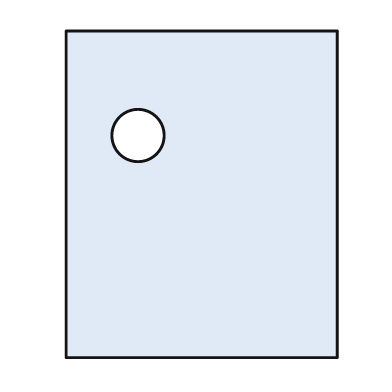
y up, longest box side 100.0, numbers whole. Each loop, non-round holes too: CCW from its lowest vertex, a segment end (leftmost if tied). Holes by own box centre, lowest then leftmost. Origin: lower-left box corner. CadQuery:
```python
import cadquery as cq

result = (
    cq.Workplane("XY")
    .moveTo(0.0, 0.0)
    .lineTo(83.0, 0.0)
    .lineTo(83.0, 100.0)
    .lineTo(0.0, 100.0)
    .close()
    .moveTo(22.0, 68.0)
    .circle(8.0)
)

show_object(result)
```